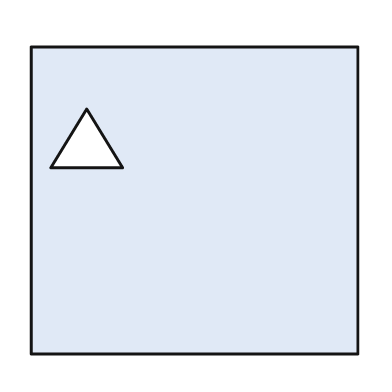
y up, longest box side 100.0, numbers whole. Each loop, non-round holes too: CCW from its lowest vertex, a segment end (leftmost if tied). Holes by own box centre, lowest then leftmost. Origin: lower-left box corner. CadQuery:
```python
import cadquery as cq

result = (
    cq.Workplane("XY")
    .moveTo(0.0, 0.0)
    .lineTo(100.0, 0.0)
    .lineTo(100.0, 94.0)
    .lineTo(0.0, 94.0)
    .close()
    .moveTo(6.0, 57.0)
    .lineTo(28.0, 57.0)
    .lineTo(17.0, 75.0)
    .close()
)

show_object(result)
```